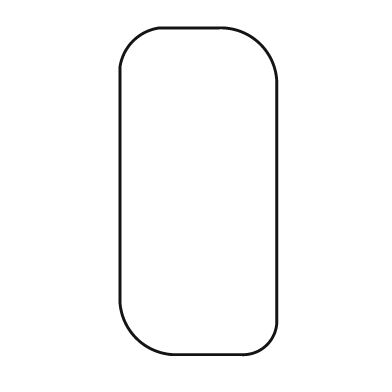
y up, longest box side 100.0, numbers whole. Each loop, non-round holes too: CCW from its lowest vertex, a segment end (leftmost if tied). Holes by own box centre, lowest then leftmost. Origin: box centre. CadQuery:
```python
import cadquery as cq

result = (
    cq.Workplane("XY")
    .moveTo(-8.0, -50.0)
    .lineTo(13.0, -50.0)
    .threePointArc((21.0, -47.0), (24.0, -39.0))
    .lineTo(24.0, 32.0)
    .threePointArc((19.0, 45.0), (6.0, 50.0))
    .lineTo(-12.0, 50.0)
    .threePointArc((-20.0, 46.0), (-24.0, 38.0))
    .lineTo(-24.0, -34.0)
    .threePointArc((-19.0, -45.0), (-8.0, -50.0))
    .close()
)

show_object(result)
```